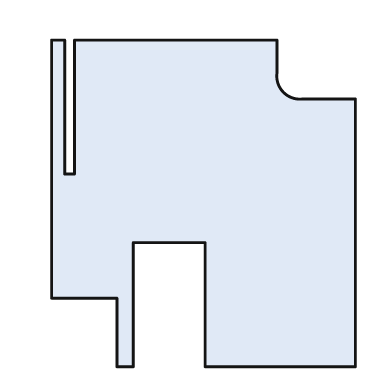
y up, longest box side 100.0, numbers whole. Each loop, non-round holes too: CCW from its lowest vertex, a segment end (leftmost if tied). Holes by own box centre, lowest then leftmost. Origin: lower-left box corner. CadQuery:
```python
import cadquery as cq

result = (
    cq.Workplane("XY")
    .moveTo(20.0, 0.0)
    .lineTo(25.0, 0.0)
    .lineTo(25.0, 38.0)
    .lineTo(47.0, 38.0)
    .lineTo(47.0, 0.0)
    .lineTo(93.0, 0.0)
    .lineTo(93.0, 82.0)
    .lineTo(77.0, 82.0)
    .threePointArc((71.0, 84.0), (69.0, 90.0))
    .lineTo(69.0, 100.0)
    .lineTo(7.0, 100.0)
    .lineTo(7.0, 59.0)
    .lineTo(4.0, 59.0)
    .lineTo(4.0, 100.0)
    .lineTo(0.0, 100.0)
    .lineTo(0.0, 21.0)
    .lineTo(20.0, 21.0)
    .close()
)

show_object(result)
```